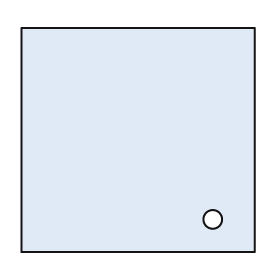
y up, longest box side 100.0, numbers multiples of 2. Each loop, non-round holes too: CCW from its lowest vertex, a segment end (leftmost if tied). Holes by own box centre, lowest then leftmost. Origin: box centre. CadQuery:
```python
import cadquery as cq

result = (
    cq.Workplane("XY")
    .moveTo(-50.0, -48.0)
    .lineTo(50.0, -48.0)
    .lineTo(50.0, 48.0)
    .lineTo(-50.0, 48.0)
    .close()
    .moveTo(32.0, -34.0)
    .circle(4.0)
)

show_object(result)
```